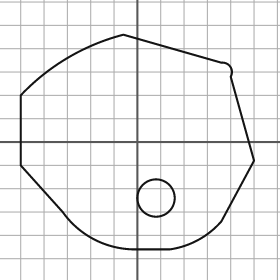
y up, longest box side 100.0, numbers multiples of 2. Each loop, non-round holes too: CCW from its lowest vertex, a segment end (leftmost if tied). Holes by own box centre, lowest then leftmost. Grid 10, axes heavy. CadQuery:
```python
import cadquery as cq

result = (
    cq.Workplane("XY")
    .moveTo(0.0, -46.0)
    .lineTo(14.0, -46.0)
    .threePointArc((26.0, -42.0), (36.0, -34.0))
    .lineTo(50.0, -8.0)
    .lineTo(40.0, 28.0)
    .threePointArc((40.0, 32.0), (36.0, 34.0))
    .lineTo(-6.0, 46.0)
    .threePointArc((-30.0, 36.0), (-50.0, 20.0))
    .lineTo(-50.0, -10.0)
    .lineTo(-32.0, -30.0)
    .threePointArc((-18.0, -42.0), (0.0, -46.0))
    .close()
    .moveTo(8.0, -24.0)
    .circle(8.0)
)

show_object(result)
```